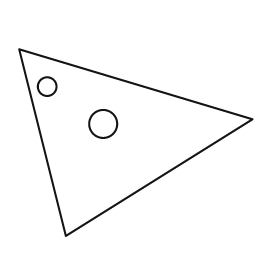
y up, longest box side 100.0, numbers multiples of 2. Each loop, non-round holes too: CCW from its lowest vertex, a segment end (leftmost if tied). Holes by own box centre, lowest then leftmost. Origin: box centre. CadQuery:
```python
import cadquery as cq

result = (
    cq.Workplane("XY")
    .moveTo(-30.0, -40.0)
    .lineTo(50.0, 10.0)
    .lineTo(-50.0, 40.0)
    .close()
    .moveTo(-14.0, 8.0)
    .circle(6.0)
    .moveTo(-38.0, 24.0)
    .circle(4.0)
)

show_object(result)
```